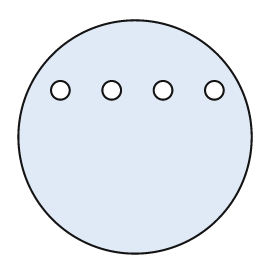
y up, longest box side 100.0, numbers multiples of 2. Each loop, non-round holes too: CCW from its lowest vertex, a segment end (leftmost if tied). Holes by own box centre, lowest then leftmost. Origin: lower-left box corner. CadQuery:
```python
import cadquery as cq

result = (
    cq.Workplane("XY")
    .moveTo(50.0, 50.0)
    .circle(50.0)
    .moveTo(18.0, 70.0)
    .circle(4.0)
    .moveTo(40.0, 70.0)
    .circle(4.0)
    .moveTo(62.0, 70.0)
    .circle(4.0)
    .moveTo(84.0, 70.0)
    .circle(4.0)
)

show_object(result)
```